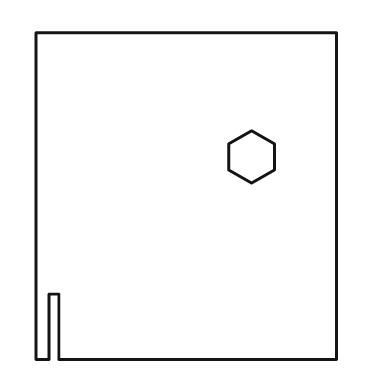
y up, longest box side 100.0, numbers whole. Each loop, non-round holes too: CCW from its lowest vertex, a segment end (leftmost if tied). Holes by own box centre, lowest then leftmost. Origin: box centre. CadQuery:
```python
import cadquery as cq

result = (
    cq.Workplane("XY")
    .moveTo(-46.0, -50.0)
    .lineTo(-42.0, -50.0)
    .lineTo(-42.0, -30.0)
    .lineTo(-39.0, -30.0)
    .lineTo(-39.0, -50.0)
    .lineTo(46.0, -50.0)
    .lineTo(46.0, 50.0)
    .lineTo(-46.0, 50.0)
    .close()
    .moveTo(20.0, 4.0)
    .lineTo(27.0, 8.0)
    .lineTo(27.0, 16.0)
    .lineTo(20.0, 20.0)
    .lineTo(13.0, 16.0)
    .lineTo(13.0, 8.0)
    .close()
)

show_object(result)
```